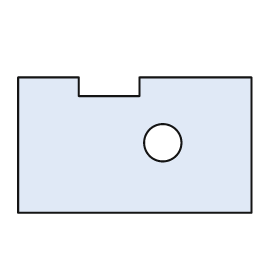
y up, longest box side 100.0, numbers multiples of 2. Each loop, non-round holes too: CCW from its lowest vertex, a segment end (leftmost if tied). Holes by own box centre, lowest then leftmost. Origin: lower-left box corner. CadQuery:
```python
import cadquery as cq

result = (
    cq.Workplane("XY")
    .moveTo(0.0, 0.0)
    .lineTo(100.0, 0.0)
    .lineTo(100.0, 58.0)
    .lineTo(52.0, 58.0)
    .lineTo(52.0, 50.0)
    .lineTo(26.0, 50.0)
    .lineTo(26.0, 58.0)
    .lineTo(0.0, 58.0)
    .close()
    .moveTo(62.0, 30.0)
    .circle(8.0)
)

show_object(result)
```